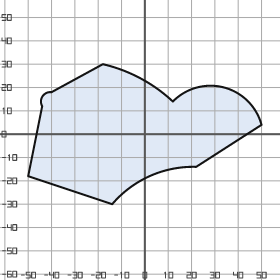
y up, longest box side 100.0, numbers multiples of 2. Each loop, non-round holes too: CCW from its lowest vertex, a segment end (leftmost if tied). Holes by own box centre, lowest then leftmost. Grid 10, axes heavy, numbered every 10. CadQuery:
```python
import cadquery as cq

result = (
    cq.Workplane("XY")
    .moveTo(-14.0, -30.0)
    .threePointArc((2.0, -18.0), (22.0, -14.0))
    .lineTo(50.0, 4.0)
    .threePointArc((34.0, 20.0), (12.0, 14.0))
    .threePointArc((-2.0, 24.0), (-18.0, 30.0))
    .lineTo(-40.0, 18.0)
    .threePointArc((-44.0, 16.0), (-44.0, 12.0))
    .lineTo(-50.0, -18.0)
    .close()
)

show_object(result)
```